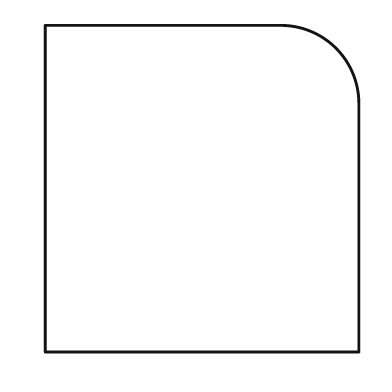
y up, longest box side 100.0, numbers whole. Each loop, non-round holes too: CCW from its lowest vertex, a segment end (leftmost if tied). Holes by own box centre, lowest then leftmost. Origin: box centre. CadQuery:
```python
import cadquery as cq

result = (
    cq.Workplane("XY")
    .moveTo(-48.0, -50.0)
    .lineTo(48.0, -50.0)
    .lineTo(48.0, 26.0)
    .threePointArc((41.0, 43.0), (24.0, 50.0))
    .lineTo(-48.0, 50.0)
    .close()
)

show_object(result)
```